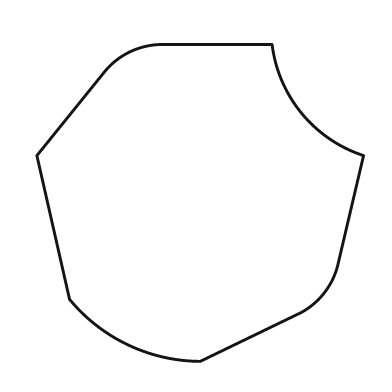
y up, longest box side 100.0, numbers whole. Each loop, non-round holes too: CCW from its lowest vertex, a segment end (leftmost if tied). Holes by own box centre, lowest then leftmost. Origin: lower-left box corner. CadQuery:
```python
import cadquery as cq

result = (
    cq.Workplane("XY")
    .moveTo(50.0, 0.0)
    .lineTo(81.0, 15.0)
    .threePointArc((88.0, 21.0), (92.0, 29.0))
    .lineTo(100.0, 63.0)
    .threePointArc((81.0, 76.0), (72.0, 97.0))
    .lineTo(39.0, 97.0)
    .threePointArc((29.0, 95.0), (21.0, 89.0))
    .lineTo(0.0, 63.0)
    .lineTo(10.0, 19.0)
    .threePointArc((28.0, 5.0), (50.0, 0.0))
    .close()
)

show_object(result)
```